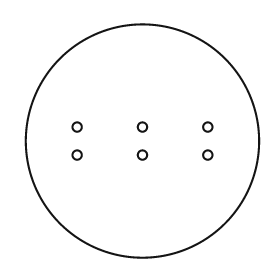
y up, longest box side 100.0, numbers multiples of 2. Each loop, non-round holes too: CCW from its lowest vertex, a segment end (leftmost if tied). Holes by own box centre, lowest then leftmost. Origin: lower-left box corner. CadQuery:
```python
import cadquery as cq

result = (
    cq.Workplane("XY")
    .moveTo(50.0, 50.0)
    .circle(50.0)
    .moveTo(22.0, 44.0)
    .circle(2.0)
    .moveTo(50.0, 44.0)
    .circle(2.0)
    .moveTo(78.0, 44.0)
    .circle(2.0)
    .moveTo(22.0, 56.0)
    .circle(2.0)
    .moveTo(50.0, 56.0)
    .circle(2.0)
    .moveTo(78.0, 56.0)
    .circle(2.0)
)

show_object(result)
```